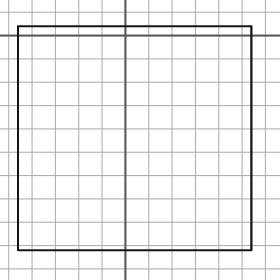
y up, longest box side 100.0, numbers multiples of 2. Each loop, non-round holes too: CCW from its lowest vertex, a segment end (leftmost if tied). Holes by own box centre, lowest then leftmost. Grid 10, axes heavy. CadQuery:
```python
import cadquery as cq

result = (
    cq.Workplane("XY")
    .moveTo(-46.0, -92.0)
    .lineTo(54.0, -92.0)
    .lineTo(54.0, 4.0)
    .lineTo(-46.0, 4.0)
    .close()
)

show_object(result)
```